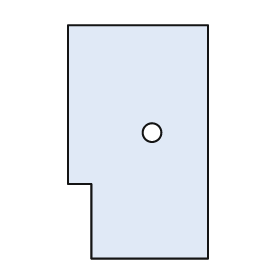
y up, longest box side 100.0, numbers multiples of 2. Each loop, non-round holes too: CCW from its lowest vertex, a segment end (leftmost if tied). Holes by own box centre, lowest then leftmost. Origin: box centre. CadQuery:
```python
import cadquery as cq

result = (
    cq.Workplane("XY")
    .moveTo(-20.0, -50.0)
    .lineTo(30.0, -50.0)
    .lineTo(30.0, 50.0)
    .lineTo(-30.0, 50.0)
    .lineTo(-30.0, -18.0)
    .lineTo(-20.0, -18.0)
    .close()
    .moveTo(6.0, 4.0)
    .circle(4.0)
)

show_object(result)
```